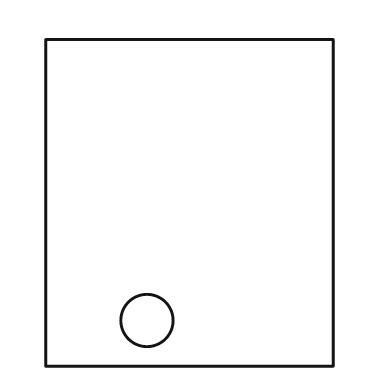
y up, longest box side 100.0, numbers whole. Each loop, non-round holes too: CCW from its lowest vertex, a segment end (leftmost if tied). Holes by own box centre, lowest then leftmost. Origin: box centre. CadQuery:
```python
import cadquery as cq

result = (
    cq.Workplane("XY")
    .moveTo(-44.0, -50.0)
    .lineTo(44.0, -50.0)
    .lineTo(44.0, 50.0)
    .lineTo(-44.0, 50.0)
    .close()
    .moveTo(-13.0, -36.0)
    .circle(8.0)
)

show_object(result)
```